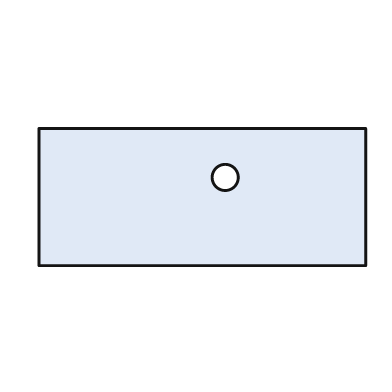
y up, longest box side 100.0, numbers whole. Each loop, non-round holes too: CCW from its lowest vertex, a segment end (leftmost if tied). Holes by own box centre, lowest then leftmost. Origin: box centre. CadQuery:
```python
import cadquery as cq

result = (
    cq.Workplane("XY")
    .moveTo(-50.0, -21.0)
    .lineTo(50.0, -21.0)
    .lineTo(50.0, 21.0)
    .lineTo(-50.0, 21.0)
    .close()
    .moveTo(7.0, 6.0)
    .circle(4.0)
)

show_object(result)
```